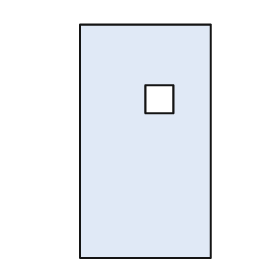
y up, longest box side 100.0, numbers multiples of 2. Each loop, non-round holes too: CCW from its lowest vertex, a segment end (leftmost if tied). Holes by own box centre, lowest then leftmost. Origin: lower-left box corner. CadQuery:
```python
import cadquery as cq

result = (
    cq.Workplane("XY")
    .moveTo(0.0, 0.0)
    .lineTo(56.0, 0.0)
    .lineTo(56.0, 100.0)
    .lineTo(0.0, 100.0)
    .close()
    .moveTo(28.0, 62.0)
    .lineTo(40.0, 62.0)
    .lineTo(40.0, 74.0)
    .lineTo(28.0, 74.0)
    .close()
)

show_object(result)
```